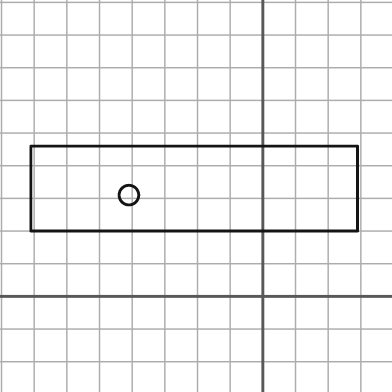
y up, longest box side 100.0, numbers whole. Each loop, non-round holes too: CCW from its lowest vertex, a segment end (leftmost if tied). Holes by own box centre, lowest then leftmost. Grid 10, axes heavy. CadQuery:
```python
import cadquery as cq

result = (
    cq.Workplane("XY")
    .moveTo(-71.0, 20.0)
    .lineTo(29.0, 20.0)
    .lineTo(29.0, 46.0)
    .lineTo(-71.0, 46.0)
    .close()
    .moveTo(-41.0, 31.0)
    .circle(3.0)
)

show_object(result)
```